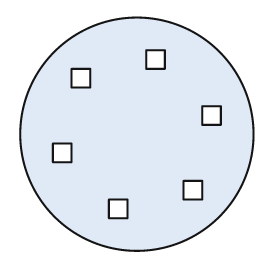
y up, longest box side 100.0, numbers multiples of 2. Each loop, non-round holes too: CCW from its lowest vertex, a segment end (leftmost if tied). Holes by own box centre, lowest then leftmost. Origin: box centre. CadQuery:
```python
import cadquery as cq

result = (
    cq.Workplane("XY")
    .moveTo(0.0, 0.0)
    .circle(50.0)
    .moveTo(-12.0, -36.0)
    .lineTo(-4.0, -36.0)
    .lineTo(-4.0, -28.0)
    .lineTo(-12.0, -28.0)
    .close()
    .moveTo(20.0, -28.0)
    .lineTo(28.0, -28.0)
    .lineTo(28.0, -20.0)
    .lineTo(20.0, -20.0)
    .close()
    .moveTo(-36.0, -12.0)
    .lineTo(-28.0, -12.0)
    .lineTo(-28.0, -4.0)
    .lineTo(-36.0, -4.0)
    .close()
    .moveTo(28.0, 4.0)
    .lineTo(36.0, 4.0)
    .lineTo(36.0, 12.0)
    .lineTo(28.0, 12.0)
    .close()
    .moveTo(-28.0, 20.0)
    .lineTo(-20.0, 20.0)
    .lineTo(-20.0, 28.0)
    .lineTo(-28.0, 28.0)
    .close()
    .moveTo(4.0, 28.0)
    .lineTo(12.0, 28.0)
    .lineTo(12.0, 36.0)
    .lineTo(4.0, 36.0)
    .close()
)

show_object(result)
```